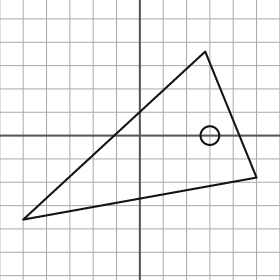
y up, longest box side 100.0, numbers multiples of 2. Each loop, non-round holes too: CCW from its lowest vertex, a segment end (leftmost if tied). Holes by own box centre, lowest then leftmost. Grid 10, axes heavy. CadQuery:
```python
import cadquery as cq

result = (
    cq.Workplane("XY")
    .moveTo(-50.0, -36.0)
    .lineTo(50.0, -18.0)
    .lineTo(28.0, 36.0)
    .close()
    .moveTo(30.0, 0.0)
    .circle(4.0)
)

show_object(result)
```